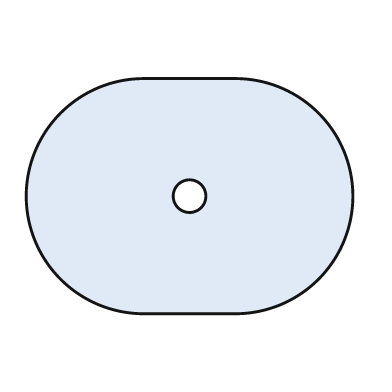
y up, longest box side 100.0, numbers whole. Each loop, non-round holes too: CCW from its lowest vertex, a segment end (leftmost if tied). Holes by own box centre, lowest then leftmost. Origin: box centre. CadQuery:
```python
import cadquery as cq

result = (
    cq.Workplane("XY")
    .moveTo(-14.0, -36.0)
    .lineTo(14.0, -36.0)
    .threePointArc((50.0, 0.0), (14.0, 36.0))
    .lineTo(-14.0, 36.0)
    .threePointArc((-50.0, 0.0), (-14.0, -36.0))
    .close()
    .moveTo(0.0, 0.0)
    .circle(5.0)
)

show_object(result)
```